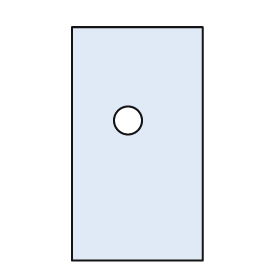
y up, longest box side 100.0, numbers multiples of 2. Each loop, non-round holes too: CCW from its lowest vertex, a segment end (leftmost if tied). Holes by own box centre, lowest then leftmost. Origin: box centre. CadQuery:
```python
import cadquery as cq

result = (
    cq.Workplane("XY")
    .moveTo(-28.0, -50.0)
    .lineTo(28.0, -50.0)
    .lineTo(28.0, 50.0)
    .lineTo(-28.0, 50.0)
    .close()
    .moveTo(-4.0, 10.0)
    .circle(6.0)
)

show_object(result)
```